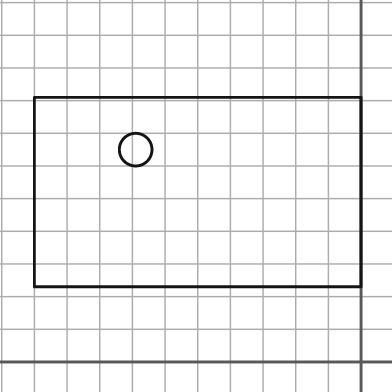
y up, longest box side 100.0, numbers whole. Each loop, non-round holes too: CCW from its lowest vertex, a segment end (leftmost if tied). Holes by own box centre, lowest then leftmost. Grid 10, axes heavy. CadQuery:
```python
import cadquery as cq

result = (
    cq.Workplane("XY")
    .moveTo(-100.0, 23.0)
    .lineTo(0.0, 23.0)
    .lineTo(0.0, 81.0)
    .lineTo(-100.0, 81.0)
    .close()
    .moveTo(-69.0, 65.0)
    .circle(5.0)
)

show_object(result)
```